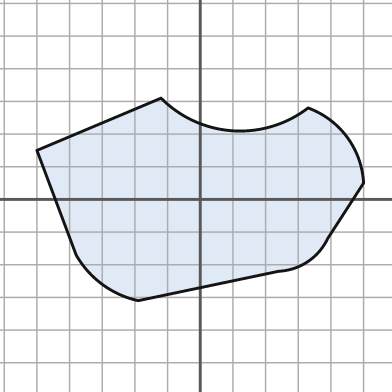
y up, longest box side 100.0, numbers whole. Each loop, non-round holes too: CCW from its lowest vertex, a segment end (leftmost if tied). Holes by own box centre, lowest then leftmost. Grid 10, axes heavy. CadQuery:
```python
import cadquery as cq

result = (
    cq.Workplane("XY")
    .moveTo(-19.0, -31.0)
    .lineTo(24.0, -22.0)
    .threePointArc((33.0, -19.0), (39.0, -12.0))
    .lineTo(50.0, 5.0)
    .threePointArc((45.0, 19.0), (33.0, 28.0))
    .threePointArc((10.0, 21.0), (-12.0, 31.0))
    .lineTo(-50.0, 15.0)
    .lineTo(-38.0, -17.0)
    .threePointArc((-30.0, -26.0), (-19.0, -31.0))
    .close()
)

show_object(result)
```